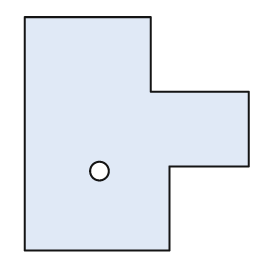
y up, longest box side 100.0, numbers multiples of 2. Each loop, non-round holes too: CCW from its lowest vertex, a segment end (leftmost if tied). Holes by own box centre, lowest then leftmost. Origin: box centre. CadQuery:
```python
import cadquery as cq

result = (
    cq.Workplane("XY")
    .moveTo(-48.0, -50.0)
    .lineTo(14.0, -50.0)
    .lineTo(14.0, -14.0)
    .lineTo(48.0, -14.0)
    .lineTo(48.0, 18.0)
    .lineTo(6.0, 18.0)
    .lineTo(6.0, 50.0)
    .lineTo(-48.0, 50.0)
    .close()
    .moveTo(-16.0, -16.0)
    .circle(4.0)
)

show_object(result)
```